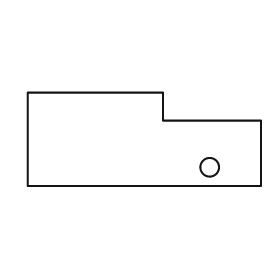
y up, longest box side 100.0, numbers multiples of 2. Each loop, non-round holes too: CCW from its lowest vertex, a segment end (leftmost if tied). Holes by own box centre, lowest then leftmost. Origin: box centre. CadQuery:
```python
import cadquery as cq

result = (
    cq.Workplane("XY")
    .moveTo(-50.0, -20.0)
    .lineTo(50.0, -20.0)
    .lineTo(50.0, 8.0)
    .lineTo(8.0, 8.0)
    .lineTo(8.0, 20.0)
    .lineTo(-50.0, 20.0)
    .close()
    .moveTo(28.0, -12.0)
    .circle(4.0)
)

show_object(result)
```